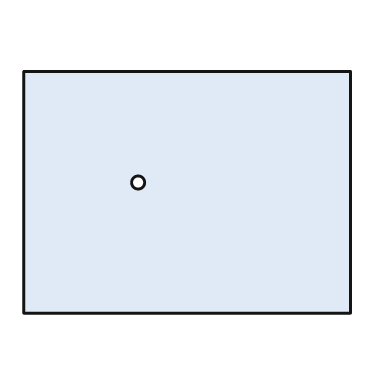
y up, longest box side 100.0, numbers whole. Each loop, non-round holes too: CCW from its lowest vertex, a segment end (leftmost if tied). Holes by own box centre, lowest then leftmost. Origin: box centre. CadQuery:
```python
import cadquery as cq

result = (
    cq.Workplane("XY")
    .moveTo(-50.0, -37.0)
    .lineTo(50.0, -37.0)
    .lineTo(50.0, 37.0)
    .lineTo(-50.0, 37.0)
    .close()
    .moveTo(-15.0, 3.0)
    .circle(2.0)
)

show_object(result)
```